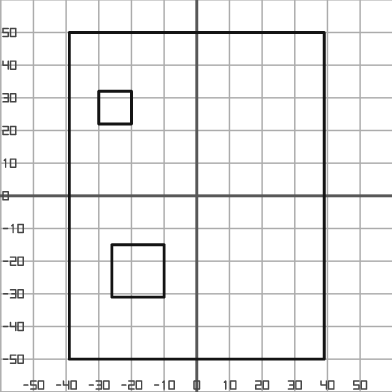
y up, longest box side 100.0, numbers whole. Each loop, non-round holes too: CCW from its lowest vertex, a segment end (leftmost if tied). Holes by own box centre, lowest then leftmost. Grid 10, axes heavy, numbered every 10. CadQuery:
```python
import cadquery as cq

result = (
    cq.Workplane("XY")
    .moveTo(-39.0, -50.0)
    .lineTo(39.0, -50.0)
    .lineTo(39.0, 50.0)
    .lineTo(-39.0, 50.0)
    .close()
    .moveTo(-26.0, -31.0)
    .lineTo(-10.0, -31.0)
    .lineTo(-10.0, -15.0)
    .lineTo(-26.0, -15.0)
    .close()
    .moveTo(-30.0, 22.0)
    .lineTo(-20.0, 22.0)
    .lineTo(-20.0, 32.0)
    .lineTo(-30.0, 32.0)
    .close()
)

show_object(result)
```